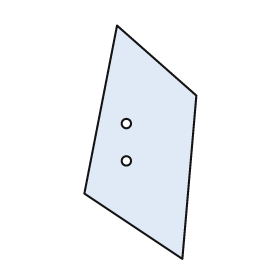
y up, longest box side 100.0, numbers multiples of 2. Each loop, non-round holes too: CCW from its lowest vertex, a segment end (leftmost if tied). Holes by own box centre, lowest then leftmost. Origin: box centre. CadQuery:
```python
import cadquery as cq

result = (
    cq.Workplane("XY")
    .moveTo(18.0, -50.0)
    .lineTo(24.0, 20.0)
    .lineTo(-10.0, 50.0)
    .lineTo(-24.0, -22.0)
    .close()
    .moveTo(-6.0, -8.0)
    .circle(2.0)
    .moveTo(-6.0, 8.0)
    .circle(2.0)
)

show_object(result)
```